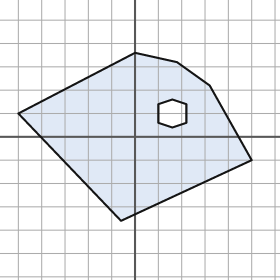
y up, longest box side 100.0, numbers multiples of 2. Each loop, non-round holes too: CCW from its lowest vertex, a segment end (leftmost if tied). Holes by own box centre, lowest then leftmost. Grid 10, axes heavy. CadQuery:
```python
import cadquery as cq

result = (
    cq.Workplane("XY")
    .moveTo(-6.0, -36.0)
    .lineTo(50.0, -10.0)
    .lineTo(32.0, 22.0)
    .lineTo(18.0, 32.0)
    .lineTo(0.0, 36.0)
    .lineTo(-50.0, 10.0)
    .close()
    .moveTo(16.0, 4.0)
    .lineTo(22.0, 6.0)
    .lineTo(22.0, 14.0)
    .lineTo(16.0, 16.0)
    .lineTo(10.0, 14.0)
    .lineTo(10.0, 6.0)
    .close()
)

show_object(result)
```